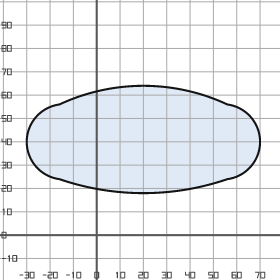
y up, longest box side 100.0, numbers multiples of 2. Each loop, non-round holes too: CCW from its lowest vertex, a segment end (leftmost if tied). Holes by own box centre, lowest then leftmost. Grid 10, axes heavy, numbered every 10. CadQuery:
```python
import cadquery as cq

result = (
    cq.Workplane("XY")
    .moveTo(-16.0, 24.0)
    .threePointArc((20.0, 18.0), (56.0, 24.0))
    .threePointArc((70.0, 40.0), (56.0, 56.0))
    .threePointArc((20.0, 64.0), (-16.0, 56.0))
    .threePointArc((-30.0, 40.0), (-16.0, 24.0))
    .close()
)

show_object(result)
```